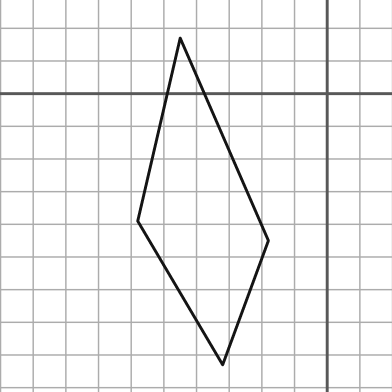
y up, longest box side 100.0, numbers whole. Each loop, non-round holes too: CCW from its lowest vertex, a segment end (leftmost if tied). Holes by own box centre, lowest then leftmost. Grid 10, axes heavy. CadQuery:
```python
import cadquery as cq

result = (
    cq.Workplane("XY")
    .moveTo(-32.0, -83.0)
    .lineTo(-18.0, -45.0)
    .lineTo(-45.0, 17.0)
    .lineTo(-58.0, -39.0)
    .close()
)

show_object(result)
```